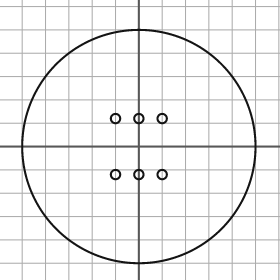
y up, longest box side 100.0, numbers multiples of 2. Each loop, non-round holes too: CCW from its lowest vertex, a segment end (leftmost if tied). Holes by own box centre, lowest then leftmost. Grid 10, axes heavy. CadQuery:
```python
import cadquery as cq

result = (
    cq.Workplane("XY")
    .moveTo(0.0, 0.0)
    .circle(50.0)
    .moveTo(-10.0, -12.0)
    .circle(2.0)
    .moveTo(0.0, -12.0)
    .circle(2.0)
    .moveTo(10.0, -12.0)
    .circle(2.0)
    .moveTo(-10.0, 12.0)
    .circle(2.0)
    .moveTo(0.0, 12.0)
    .circle(2.0)
    .moveTo(10.0, 12.0)
    .circle(2.0)
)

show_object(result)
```